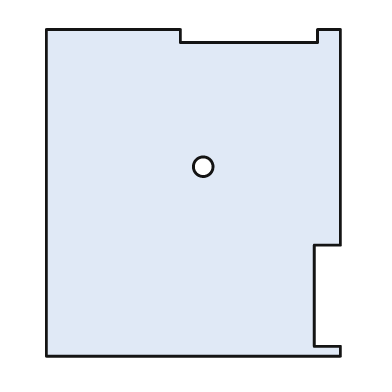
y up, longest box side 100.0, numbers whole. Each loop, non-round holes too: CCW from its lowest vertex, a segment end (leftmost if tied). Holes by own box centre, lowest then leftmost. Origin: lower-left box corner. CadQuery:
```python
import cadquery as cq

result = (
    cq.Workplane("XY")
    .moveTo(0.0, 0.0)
    .lineTo(90.0, 0.0)
    .lineTo(90.0, 3.0)
    .lineTo(82.0, 3.0)
    .lineTo(82.0, 34.0)
    .lineTo(90.0, 34.0)
    .lineTo(90.0, 100.0)
    .lineTo(83.0, 100.0)
    .lineTo(83.0, 96.0)
    .lineTo(41.0, 96.0)
    .lineTo(41.0, 100.0)
    .lineTo(0.0, 100.0)
    .close()
    .moveTo(48.0, 58.0)
    .circle(3.0)
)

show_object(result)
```